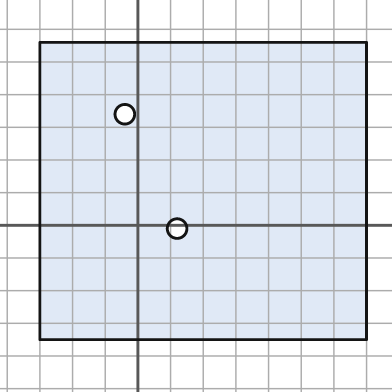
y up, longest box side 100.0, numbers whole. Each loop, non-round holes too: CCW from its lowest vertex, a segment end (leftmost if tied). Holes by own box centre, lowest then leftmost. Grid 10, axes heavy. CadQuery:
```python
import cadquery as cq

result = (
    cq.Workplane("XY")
    .moveTo(-30.0, -35.0)
    .lineTo(70.0, -35.0)
    .lineTo(70.0, 56.0)
    .lineTo(-30.0, 56.0)
    .close()
    .moveTo(12.0, -1.0)
    .circle(3.0)
    .moveTo(-4.0, 34.0)
    .circle(3.0)
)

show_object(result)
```